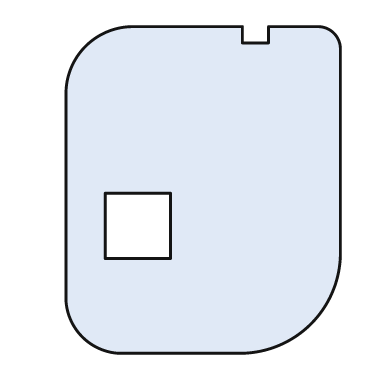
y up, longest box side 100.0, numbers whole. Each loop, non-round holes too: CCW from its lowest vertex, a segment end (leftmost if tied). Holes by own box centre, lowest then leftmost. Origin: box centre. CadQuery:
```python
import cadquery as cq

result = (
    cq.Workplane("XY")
    .moveTo(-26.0, -50.0)
    .lineTo(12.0, -50.0)
    .threePointArc((33.0, -41.0), (42.0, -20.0))
    .lineTo(42.0, 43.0)
    .threePointArc((40.0, 48.0), (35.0, 50.0))
    .lineTo(20.0, 50.0)
    .lineTo(20.0, 45.0)
    .lineTo(12.0, 45.0)
    .lineTo(12.0, 50.0)
    .lineTo(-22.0, 50.0)
    .threePointArc((-36.0, 44.0), (-42.0, 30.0))
    .lineTo(-42.0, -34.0)
    .threePointArc((-37.0, -45.0), (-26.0, -50.0))
    .close()
    .moveTo(-30.0, -21.0)
    .lineTo(-10.0, -21.0)
    .lineTo(-10.0, -1.0)
    .lineTo(-30.0, -1.0)
    .close()
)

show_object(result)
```